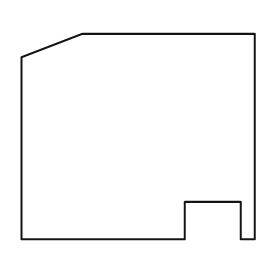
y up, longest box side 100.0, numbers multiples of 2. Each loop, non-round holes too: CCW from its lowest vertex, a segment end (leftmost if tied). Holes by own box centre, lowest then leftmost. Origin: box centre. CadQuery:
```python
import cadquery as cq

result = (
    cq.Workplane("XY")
    .moveTo(-50.0, -44.0)
    .lineTo(20.0, -44.0)
    .lineTo(20.0, -28.0)
    .lineTo(44.0, -28.0)
    .lineTo(44.0, -44.0)
    .lineTo(50.0, -44.0)
    .lineTo(50.0, 44.0)
    .lineTo(-24.0, 44.0)
    .lineTo(-50.0, 34.0)
    .close()
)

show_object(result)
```